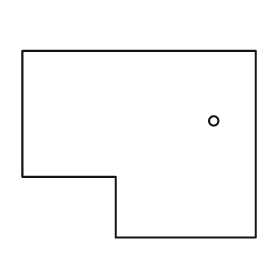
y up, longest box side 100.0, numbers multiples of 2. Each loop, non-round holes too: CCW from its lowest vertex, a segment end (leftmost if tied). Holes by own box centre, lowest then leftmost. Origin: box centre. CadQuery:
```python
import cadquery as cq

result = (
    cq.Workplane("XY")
    .moveTo(-10.0, -40.0)
    .lineTo(50.0, -40.0)
    .lineTo(50.0, 40.0)
    .lineTo(-50.0, 40.0)
    .lineTo(-50.0, -14.0)
    .lineTo(-10.0, -14.0)
    .close()
    .moveTo(32.0, 10.0)
    .circle(2.0)
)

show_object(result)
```